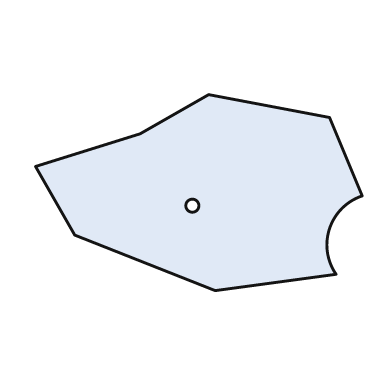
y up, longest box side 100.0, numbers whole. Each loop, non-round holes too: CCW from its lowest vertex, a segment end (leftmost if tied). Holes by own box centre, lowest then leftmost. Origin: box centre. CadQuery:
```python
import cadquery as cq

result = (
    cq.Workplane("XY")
    .moveTo(5.0, -30.0)
    .lineTo(42.0, -25.0)
    .threePointArc((40.0, -11.0), (50.0, -1.0))
    .lineTo(40.0, 23.0)
    .lineTo(3.0, 30.0)
    .lineTo(-18.0, 18.0)
    .lineTo(-50.0, 8.0)
    .lineTo(-38.0, -13.0)
    .close()
    .moveTo(-2.0, -4.0)
    .circle(2.0)
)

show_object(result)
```